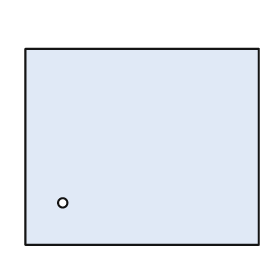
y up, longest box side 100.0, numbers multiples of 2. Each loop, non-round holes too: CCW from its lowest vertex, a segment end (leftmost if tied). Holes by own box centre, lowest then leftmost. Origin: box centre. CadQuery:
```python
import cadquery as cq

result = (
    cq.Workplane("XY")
    .moveTo(-50.0, -42.0)
    .lineTo(50.0, -42.0)
    .lineTo(50.0, 42.0)
    .lineTo(-50.0, 42.0)
    .close()
    .moveTo(-34.0, -24.0)
    .circle(2.0)
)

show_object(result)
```